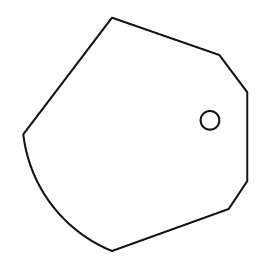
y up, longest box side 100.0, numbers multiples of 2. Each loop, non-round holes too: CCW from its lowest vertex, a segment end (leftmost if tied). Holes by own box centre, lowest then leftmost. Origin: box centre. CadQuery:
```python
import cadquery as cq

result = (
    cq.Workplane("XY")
    .moveTo(-10.0, -50.0)
    .lineTo(40.0, -32.0)
    .lineTo(48.0, -20.0)
    .lineTo(48.0, 18.0)
    .lineTo(36.0, 34.0)
    .lineTo(-10.0, 50.0)
    .lineTo(-48.0, 0.0)
    .threePointArc((-36.0, -30.0), (-10.0, -50.0))
    .close()
    .moveTo(32.0, 6.0)
    .circle(4.0)
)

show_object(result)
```